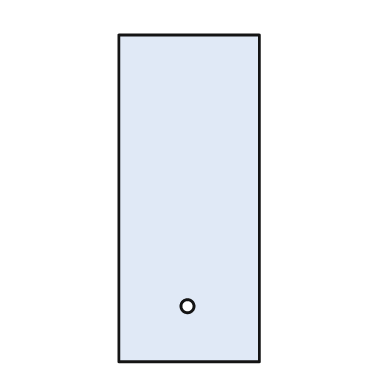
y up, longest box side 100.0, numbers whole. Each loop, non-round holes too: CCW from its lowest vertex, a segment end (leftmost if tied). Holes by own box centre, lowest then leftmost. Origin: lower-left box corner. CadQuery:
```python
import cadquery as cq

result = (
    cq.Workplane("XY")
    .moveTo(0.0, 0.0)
    .lineTo(43.0, 0.0)
    .lineTo(43.0, 100.0)
    .lineTo(0.0, 100.0)
    .close()
    .moveTo(21.0, 17.0)
    .circle(2.0)
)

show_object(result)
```